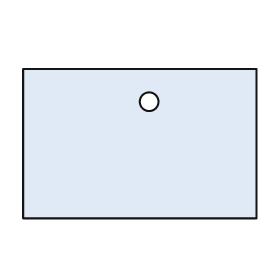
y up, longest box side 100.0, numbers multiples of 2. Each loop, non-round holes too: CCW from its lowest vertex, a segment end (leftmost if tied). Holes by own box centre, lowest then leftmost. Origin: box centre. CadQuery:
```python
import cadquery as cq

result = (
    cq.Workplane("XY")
    .moveTo(-50.0, -32.0)
    .lineTo(50.0, -32.0)
    .lineTo(50.0, 32.0)
    .lineTo(-50.0, 32.0)
    .close()
    .moveTo(4.0, 18.0)
    .circle(4.0)
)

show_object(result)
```